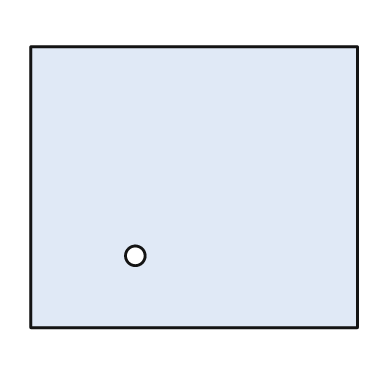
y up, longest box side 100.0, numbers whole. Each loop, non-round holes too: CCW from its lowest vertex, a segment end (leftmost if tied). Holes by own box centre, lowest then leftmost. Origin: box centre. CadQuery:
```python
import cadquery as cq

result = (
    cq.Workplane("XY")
    .moveTo(-50.0, -43.0)
    .lineTo(50.0, -43.0)
    .lineTo(50.0, 43.0)
    .lineTo(-50.0, 43.0)
    .close()
    .moveTo(-18.0, -21.0)
    .circle(3.0)
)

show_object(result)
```